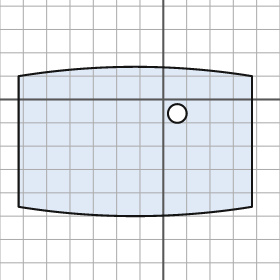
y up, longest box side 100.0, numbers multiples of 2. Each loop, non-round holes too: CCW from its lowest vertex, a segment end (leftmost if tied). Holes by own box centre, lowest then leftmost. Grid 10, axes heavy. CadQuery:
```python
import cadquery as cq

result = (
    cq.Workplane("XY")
    .moveTo(-62.0, -46.0)
    .threePointArc((-12.0, -50.0), (38.0, -46.0))
    .lineTo(38.0, 10.0)
    .threePointArc((-12.0, 14.0), (-62.0, 10.0))
    .close()
    .moveTo(6.0, -6.0)
    .circle(4.0)
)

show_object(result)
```